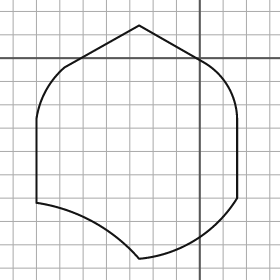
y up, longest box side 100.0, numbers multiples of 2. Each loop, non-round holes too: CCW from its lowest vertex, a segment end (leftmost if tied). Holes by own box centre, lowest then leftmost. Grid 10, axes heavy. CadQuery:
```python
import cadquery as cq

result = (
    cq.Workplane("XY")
    .moveTo(-26.0, -86.0)
    .threePointArc((-2.0, -78.0), (16.0, -60.0))
    .lineTo(16.0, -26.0)
    .threePointArc((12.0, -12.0), (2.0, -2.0))
    .lineTo(-26.0, 14.0)
    .lineTo(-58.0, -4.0)
    .threePointArc((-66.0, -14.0), (-70.0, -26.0))
    .lineTo(-70.0, -62.0)
    .threePointArc((-46.0, -70.0), (-26.0, -86.0))
    .close()
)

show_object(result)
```